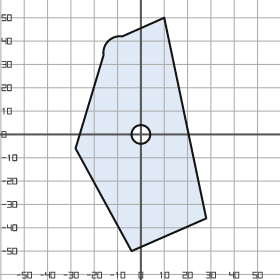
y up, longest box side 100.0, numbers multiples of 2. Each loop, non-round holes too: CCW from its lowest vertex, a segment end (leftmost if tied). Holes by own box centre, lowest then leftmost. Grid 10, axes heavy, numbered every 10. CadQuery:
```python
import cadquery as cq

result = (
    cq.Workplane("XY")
    .moveTo(-4.0, -50.0)
    .lineTo(28.0, -36.0)
    .lineTo(10.0, 50.0)
    .lineTo(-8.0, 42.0)
    .threePointArc((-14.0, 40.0), (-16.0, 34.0))
    .lineTo(-28.0, -6.0)
    .close()
    .moveTo(0.0, 0.0)
    .circle(4.0)
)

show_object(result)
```